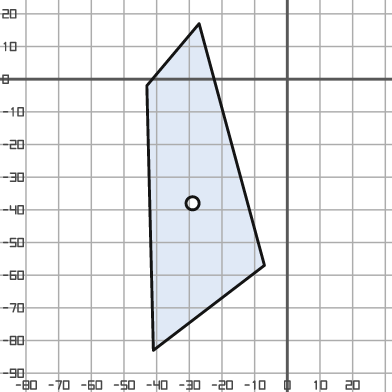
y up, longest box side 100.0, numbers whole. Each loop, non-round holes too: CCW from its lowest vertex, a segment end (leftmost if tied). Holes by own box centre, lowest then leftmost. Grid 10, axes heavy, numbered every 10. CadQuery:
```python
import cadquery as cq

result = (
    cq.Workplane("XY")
    .moveTo(-41.0, -83.0)
    .lineTo(-7.0, -57.0)
    .lineTo(-27.0, 17.0)
    .lineTo(-43.0, -2.0)
    .close()
    .moveTo(-29.0, -38.0)
    .circle(2.0)
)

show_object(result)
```